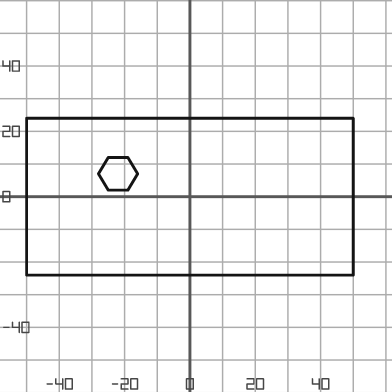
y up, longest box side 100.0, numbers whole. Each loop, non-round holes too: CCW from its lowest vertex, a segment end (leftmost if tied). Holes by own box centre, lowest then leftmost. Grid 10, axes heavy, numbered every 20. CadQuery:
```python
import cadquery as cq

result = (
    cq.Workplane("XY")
    .moveTo(-50.0, -24.0)
    .lineTo(50.0, -24.0)
    .lineTo(50.0, 24.0)
    .lineTo(-50.0, 24.0)
    .close()
    .moveTo(-25.0, 2.0)
    .lineTo(-19.0, 2.0)
    .lineTo(-16.0, 7.0)
    .lineTo(-19.0, 12.0)
    .lineTo(-25.0, 12.0)
    .lineTo(-28.0, 7.0)
    .close()
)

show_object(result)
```